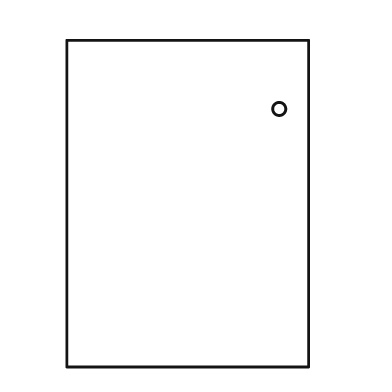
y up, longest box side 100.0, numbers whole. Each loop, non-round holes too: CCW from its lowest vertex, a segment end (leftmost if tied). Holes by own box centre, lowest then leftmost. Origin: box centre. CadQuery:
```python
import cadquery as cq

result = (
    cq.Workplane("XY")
    .moveTo(-37.0, -50.0)
    .lineTo(37.0, -50.0)
    .lineTo(37.0, 50.0)
    .lineTo(-37.0, 50.0)
    .close()
    .moveTo(28.0, 29.0)
    .circle(2.0)
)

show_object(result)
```